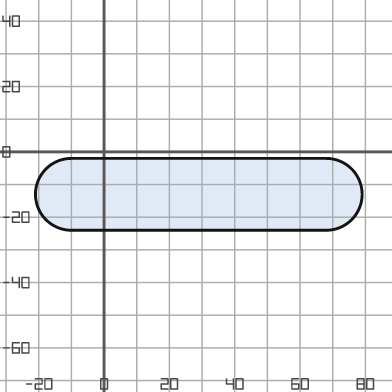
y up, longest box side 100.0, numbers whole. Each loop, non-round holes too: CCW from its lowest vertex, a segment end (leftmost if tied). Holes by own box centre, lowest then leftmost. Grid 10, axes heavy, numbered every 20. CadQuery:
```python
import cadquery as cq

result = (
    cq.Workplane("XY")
    .moveTo(-10.0, -24.0)
    .lineTo(68.0, -24.0)
    .threePointArc((79.0, -13.0), (68.0, -2.0))
    .lineTo(-10.0, -2.0)
    .threePointArc((-21.0, -13.0), (-10.0, -24.0))
    .close()
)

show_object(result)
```